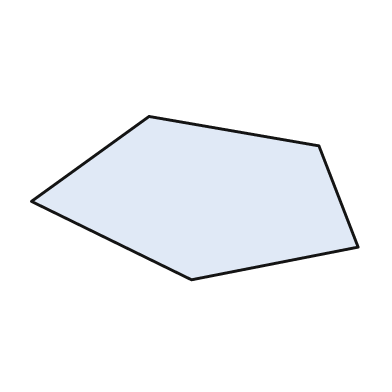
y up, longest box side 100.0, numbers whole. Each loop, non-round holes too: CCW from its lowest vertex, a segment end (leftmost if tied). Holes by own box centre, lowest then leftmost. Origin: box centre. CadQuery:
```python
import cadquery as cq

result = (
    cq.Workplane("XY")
    .moveTo(-1.0, -25.0)
    .lineTo(50.0, -15.0)
    .lineTo(38.0, 16.0)
    .lineTo(-14.0, 25.0)
    .lineTo(-50.0, -1.0)
    .close()
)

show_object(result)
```